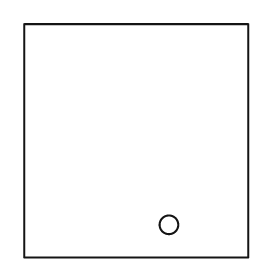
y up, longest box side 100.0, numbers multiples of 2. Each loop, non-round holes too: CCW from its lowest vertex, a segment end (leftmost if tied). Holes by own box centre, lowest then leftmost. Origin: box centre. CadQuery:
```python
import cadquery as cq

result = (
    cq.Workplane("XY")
    .moveTo(-48.0, -50.0)
    .lineTo(48.0, -50.0)
    .lineTo(48.0, 50.0)
    .lineTo(-48.0, 50.0)
    .close()
    .moveTo(14.0, -36.0)
    .circle(4.0)
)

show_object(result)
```